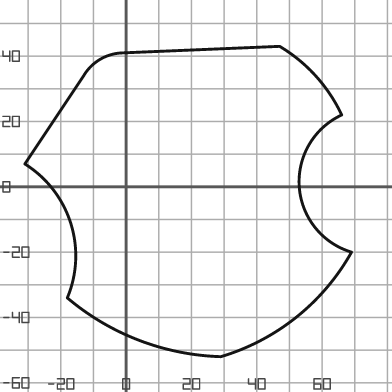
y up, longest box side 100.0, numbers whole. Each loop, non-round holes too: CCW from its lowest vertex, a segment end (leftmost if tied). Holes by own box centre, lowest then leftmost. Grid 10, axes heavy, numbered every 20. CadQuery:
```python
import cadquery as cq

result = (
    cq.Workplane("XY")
    .moveTo(29.0, -52.0)
    .threePointArc((52.0, -40.0), (69.0, -20.0))
    .threePointArc((53.0, 0.0), (66.0, 22.0))
    .threePointArc((58.0, 34.0), (47.0, 43.0))
    .lineTo(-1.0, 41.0)
    .threePointArc((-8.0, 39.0), (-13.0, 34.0))
    .lineTo(-31.0, 7.0)
    .threePointArc((-17.0, -11.0), (-18.0, -34.0))
    .threePointArc((4.0, -47.0), (29.0, -52.0))
    .close()
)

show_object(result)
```